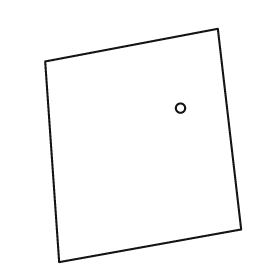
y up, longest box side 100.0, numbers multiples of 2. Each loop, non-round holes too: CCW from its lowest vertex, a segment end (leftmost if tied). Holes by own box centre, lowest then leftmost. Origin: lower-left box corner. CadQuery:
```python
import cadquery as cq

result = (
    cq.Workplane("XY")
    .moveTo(6.0, 0.0)
    .lineTo(84.0, 14.0)
    .lineTo(74.0, 100.0)
    .lineTo(0.0, 86.0)
    .close()
    .moveTo(58.0, 66.0)
    .circle(2.0)
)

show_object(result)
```